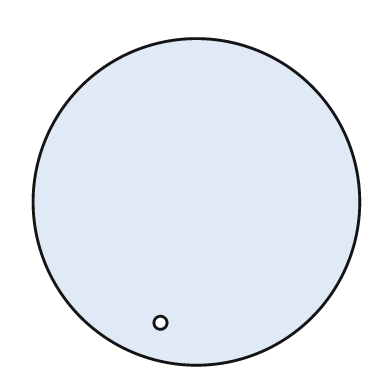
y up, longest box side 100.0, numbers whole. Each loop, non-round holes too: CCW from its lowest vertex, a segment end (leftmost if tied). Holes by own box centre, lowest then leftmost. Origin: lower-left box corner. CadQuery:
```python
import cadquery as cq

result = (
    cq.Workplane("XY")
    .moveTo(50.0, 50.0)
    .circle(50.0)
    .moveTo(39.0, 13.0)
    .circle(2.0)
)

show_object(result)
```